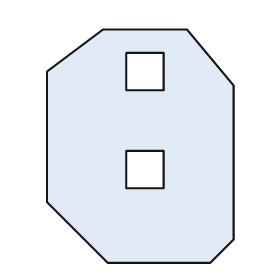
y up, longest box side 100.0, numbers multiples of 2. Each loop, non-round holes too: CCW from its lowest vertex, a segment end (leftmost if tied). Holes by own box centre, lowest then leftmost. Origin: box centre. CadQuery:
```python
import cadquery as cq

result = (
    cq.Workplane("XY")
    .moveTo(-14.0, -50.0)
    .lineTo(30.0, -50.0)
    .lineTo(40.0, -40.0)
    .lineTo(40.0, 26.0)
    .lineTo(20.0, 50.0)
    .lineTo(-16.0, 50.0)
    .lineTo(-40.0, 32.0)
    .lineTo(-40.0, -24.0)
    .close()
    .moveTo(-6.0, -18.0)
    .lineTo(10.0, -18.0)
    .lineTo(10.0, -2.0)
    .lineTo(-6.0, -2.0)
    .close()
    .moveTo(-6.0, 24.0)
    .lineTo(10.0, 24.0)
    .lineTo(10.0, 40.0)
    .lineTo(-6.0, 40.0)
    .close()
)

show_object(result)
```